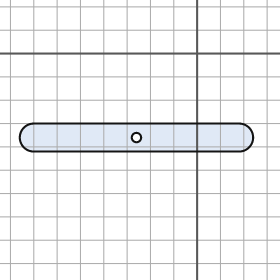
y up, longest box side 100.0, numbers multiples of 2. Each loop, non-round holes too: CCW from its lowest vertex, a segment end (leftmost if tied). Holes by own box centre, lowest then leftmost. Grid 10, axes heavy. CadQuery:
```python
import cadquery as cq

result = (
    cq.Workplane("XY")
    .moveTo(-70.0, -42.0)
    .lineTo(18.0, -42.0)
    .threePointArc((24.0, -36.0), (18.0, -30.0))
    .lineTo(-70.0, -30.0)
    .threePointArc((-76.0, -36.0), (-70.0, -42.0))
    .close()
    .moveTo(-26.0, -36.0)
    .circle(2.0)
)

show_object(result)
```